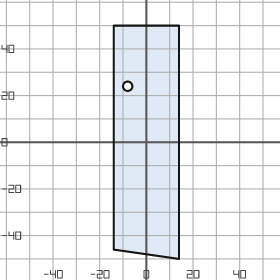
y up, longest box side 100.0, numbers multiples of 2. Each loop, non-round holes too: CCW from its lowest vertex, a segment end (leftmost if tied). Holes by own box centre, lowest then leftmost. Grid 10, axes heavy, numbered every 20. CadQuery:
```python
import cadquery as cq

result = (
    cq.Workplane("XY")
    .moveTo(14.0, -50.0)
    .lineTo(14.0, 50.0)
    .lineTo(-14.0, 50.0)
    .lineTo(-14.0, -46.0)
    .close()
    .moveTo(-8.0, 24.0)
    .circle(2.0)
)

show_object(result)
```